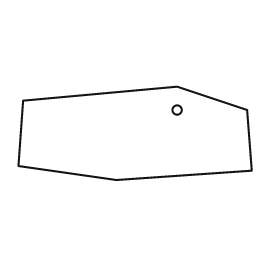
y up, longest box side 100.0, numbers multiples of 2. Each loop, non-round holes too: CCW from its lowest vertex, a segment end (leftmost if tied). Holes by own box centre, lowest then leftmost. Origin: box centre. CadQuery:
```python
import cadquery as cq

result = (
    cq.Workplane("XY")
    .moveTo(-8.0, -20.0)
    .lineTo(50.0, -16.0)
    .lineTo(48.0, 10.0)
    .lineTo(18.0, 20.0)
    .lineTo(-48.0, 14.0)
    .lineTo(-50.0, -14.0)
    .close()
    .moveTo(18.0, 10.0)
    .circle(2.0)
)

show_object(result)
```